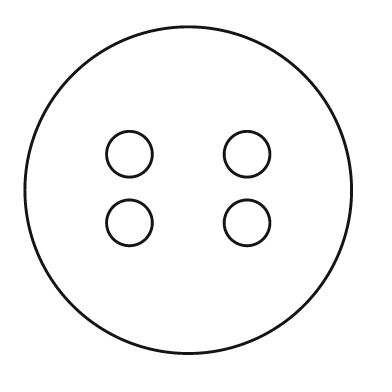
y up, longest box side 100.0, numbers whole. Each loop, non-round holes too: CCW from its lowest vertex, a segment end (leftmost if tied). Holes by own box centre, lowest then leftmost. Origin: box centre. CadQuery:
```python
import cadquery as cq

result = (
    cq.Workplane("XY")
    .moveTo(0.0, 0.0)
    .circle(50.0)
    .moveTo(-18.0, -10.0)
    .circle(7.0)
    .moveTo(18.0, -10.0)
    .circle(7.0)
    .moveTo(-18.0, 11.0)
    .circle(7.0)
    .moveTo(18.0, 11.0)
    .circle(7.0)
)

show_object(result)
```